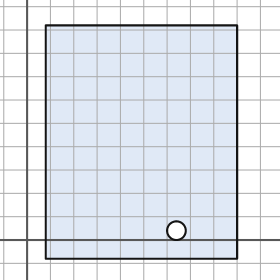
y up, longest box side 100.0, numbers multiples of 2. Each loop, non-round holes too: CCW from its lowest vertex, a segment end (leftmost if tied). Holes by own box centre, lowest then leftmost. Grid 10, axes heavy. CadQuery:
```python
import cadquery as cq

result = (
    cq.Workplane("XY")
    .moveTo(8.0, -8.0)
    .lineTo(90.0, -8.0)
    .lineTo(90.0, 92.0)
    .lineTo(8.0, 92.0)
    .close()
    .moveTo(64.0, 4.0)
    .circle(4.0)
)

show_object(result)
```